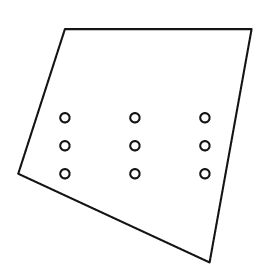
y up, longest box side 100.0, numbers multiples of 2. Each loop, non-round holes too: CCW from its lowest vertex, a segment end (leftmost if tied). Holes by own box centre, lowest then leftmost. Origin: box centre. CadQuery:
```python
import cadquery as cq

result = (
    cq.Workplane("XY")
    .moveTo(32.0, -50.0)
    .lineTo(50.0, 50.0)
    .lineTo(-30.0, 50.0)
    .lineTo(-50.0, -12.0)
    .close()
    .moveTo(-30.0, -12.0)
    .circle(2.0)
    .moveTo(0.0, -12.0)
    .circle(2.0)
    .moveTo(30.0, -12.0)
    .circle(2.0)
    .moveTo(-30.0, 0.0)
    .circle(2.0)
    .moveTo(0.0, 0.0)
    .circle(2.0)
    .moveTo(30.0, 0.0)
    .circle(2.0)
    .moveTo(-30.0, 12.0)
    .circle(2.0)
    .moveTo(0.0, 12.0)
    .circle(2.0)
    .moveTo(30.0, 12.0)
    .circle(2.0)
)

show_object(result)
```